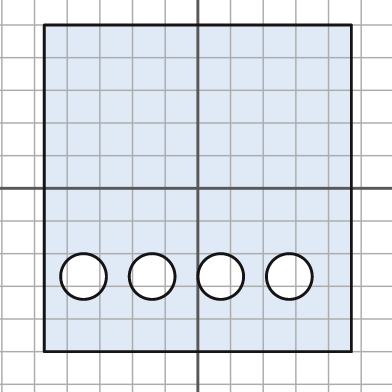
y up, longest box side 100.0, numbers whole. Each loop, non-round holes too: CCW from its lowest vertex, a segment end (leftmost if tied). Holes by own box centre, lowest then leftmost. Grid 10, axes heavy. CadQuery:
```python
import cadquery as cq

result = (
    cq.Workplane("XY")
    .moveTo(-47.0, -50.0)
    .lineTo(47.0, -50.0)
    .lineTo(47.0, 50.0)
    .lineTo(-47.0, 50.0)
    .close()
    .moveTo(-35.0, -27.0)
    .circle(7.0)
    .moveTo(-14.0, -27.0)
    .circle(7.0)
    .moveTo(7.0, -27.0)
    .circle(7.0)
    .moveTo(28.0, -27.0)
    .circle(7.0)
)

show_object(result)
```